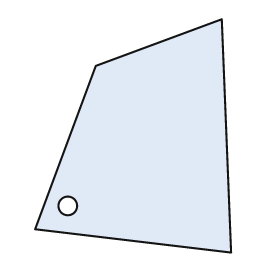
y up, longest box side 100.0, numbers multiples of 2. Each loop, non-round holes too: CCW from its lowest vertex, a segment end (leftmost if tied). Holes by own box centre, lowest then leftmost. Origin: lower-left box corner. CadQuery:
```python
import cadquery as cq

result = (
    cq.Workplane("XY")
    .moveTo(84.0, 0.0)
    .lineTo(80.0, 100.0)
    .lineTo(26.0, 80.0)
    .lineTo(0.0, 10.0)
    .close()
    .moveTo(14.0, 20.0)
    .circle(4.0)
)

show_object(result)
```